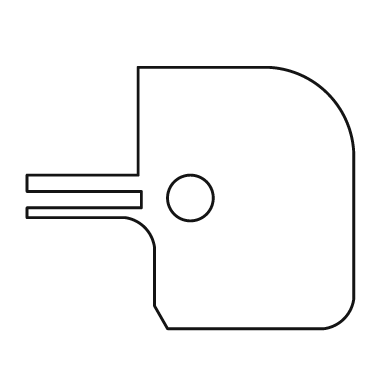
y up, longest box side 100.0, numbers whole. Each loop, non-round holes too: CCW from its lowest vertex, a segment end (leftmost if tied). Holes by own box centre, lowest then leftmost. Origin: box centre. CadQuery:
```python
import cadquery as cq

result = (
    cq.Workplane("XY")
    .moveTo(-7.0, -40.0)
    .lineTo(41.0, -40.0)
    .threePointArc((47.0, -37.0), (50.0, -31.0))
    .lineTo(50.0, 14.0)
    .threePointArc((42.0, 32.0), (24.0, 40.0))
    .lineTo(-16.0, 40.0)
    .lineTo(-16.0, 7.0)
    .lineTo(-50.0, 7.0)
    .lineTo(-50.0, 2.0)
    .lineTo(-15.0, 2.0)
    .lineTo(-15.0, -3.0)
    .lineTo(-50.0, -3.0)
    .lineTo(-50.0, -6.0)
    .lineTo(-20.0, -6.0)
    .threePointArc((-14.0, -9.0), (-11.0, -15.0))
    .lineTo(-11.0, -33.0)
    .close()
    .moveTo(0.0, 0.0)
    .circle(7.0)
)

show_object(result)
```